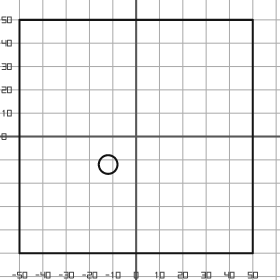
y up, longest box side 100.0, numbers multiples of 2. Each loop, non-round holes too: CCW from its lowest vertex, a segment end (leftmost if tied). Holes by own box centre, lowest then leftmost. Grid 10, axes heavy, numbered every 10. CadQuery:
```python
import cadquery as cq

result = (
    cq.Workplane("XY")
    .moveTo(-50.0, -50.0)
    .lineTo(50.0, -50.0)
    .lineTo(50.0, 50.0)
    .lineTo(-50.0, 50.0)
    .close()
    .moveTo(-12.0, -12.0)
    .circle(4.0)
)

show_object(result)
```